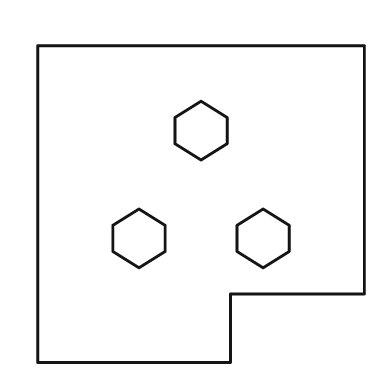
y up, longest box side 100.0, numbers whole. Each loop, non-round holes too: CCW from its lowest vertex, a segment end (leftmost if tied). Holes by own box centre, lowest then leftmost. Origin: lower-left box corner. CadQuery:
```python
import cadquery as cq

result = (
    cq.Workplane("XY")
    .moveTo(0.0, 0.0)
    .lineTo(59.0, 0.0)
    .lineTo(59.0, 21.0)
    .lineTo(100.0, 21.0)
    .lineTo(100.0, 97.0)
    .lineTo(0.0, 97.0)
    .close()
    .moveTo(31.0, 29.0)
    .lineTo(39.0, 34.0)
    .lineTo(39.0, 42.0)
    .lineTo(31.0, 47.0)
    .lineTo(23.0, 42.0)
    .lineTo(23.0, 34.0)
    .close()
    .moveTo(69.0, 29.0)
    .lineTo(77.0, 34.0)
    .lineTo(77.0, 42.0)
    .lineTo(69.0, 47.0)
    .lineTo(61.0, 42.0)
    .lineTo(61.0, 34.0)
    .close()
    .moveTo(50.0, 62.0)
    .lineTo(58.0, 67.0)
    .lineTo(58.0, 75.0)
    .lineTo(50.0, 80.0)
    .lineTo(42.0, 75.0)
    .lineTo(42.0, 67.0)
    .close()
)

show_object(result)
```